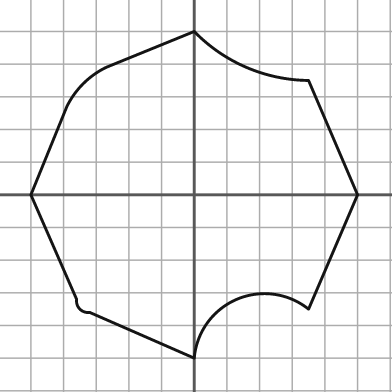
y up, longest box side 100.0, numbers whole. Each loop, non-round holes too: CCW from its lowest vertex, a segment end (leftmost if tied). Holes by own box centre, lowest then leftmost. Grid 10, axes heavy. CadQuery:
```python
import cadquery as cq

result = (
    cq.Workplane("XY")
    .moveTo(0.0, -50.0)
    .threePointArc((13.0, -32.0), (35.0, -35.0))
    .lineTo(50.0, 0.0)
    .lineTo(35.0, 35.0)
    .threePointArc((16.0, 39.0), (0.0, 50.0))
    .lineTo(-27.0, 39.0)
    .threePointArc((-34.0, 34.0), (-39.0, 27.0))
    .lineTo(-50.0, 0.0)
    .lineTo(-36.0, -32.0)
    .threePointArc((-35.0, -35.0), (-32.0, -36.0))
    .close()
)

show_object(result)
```